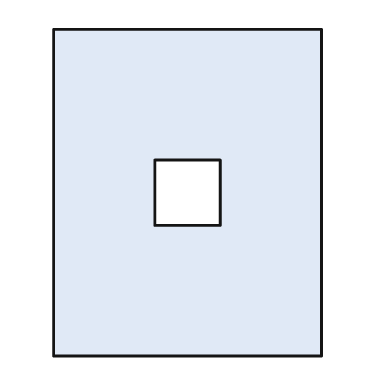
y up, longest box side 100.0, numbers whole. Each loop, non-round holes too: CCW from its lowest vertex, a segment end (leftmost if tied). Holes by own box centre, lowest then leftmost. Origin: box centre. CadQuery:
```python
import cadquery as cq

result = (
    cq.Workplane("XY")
    .moveTo(-41.0, -50.0)
    .lineTo(41.0, -50.0)
    .lineTo(41.0, 50.0)
    .lineTo(-41.0, 50.0)
    .close()
    .moveTo(-10.0, -10.0)
    .lineTo(10.0, -10.0)
    .lineTo(10.0, 10.0)
    .lineTo(-10.0, 10.0)
    .close()
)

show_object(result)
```